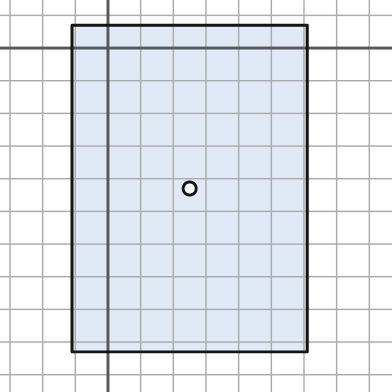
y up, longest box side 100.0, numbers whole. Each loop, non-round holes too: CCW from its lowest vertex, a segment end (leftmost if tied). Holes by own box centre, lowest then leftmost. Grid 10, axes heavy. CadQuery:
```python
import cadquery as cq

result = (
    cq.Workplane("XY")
    .moveTo(-11.0, -93.0)
    .lineTo(61.0, -93.0)
    .lineTo(61.0, 7.0)
    .lineTo(-11.0, 7.0)
    .close()
    .moveTo(25.0, -43.0)
    .circle(2.0)
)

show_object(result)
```